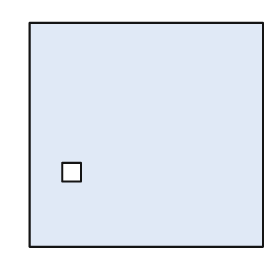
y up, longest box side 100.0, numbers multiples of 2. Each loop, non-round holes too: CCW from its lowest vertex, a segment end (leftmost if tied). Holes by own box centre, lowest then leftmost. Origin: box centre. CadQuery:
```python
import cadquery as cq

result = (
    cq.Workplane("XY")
    .moveTo(-50.0, -48.0)
    .lineTo(50.0, -48.0)
    .lineTo(50.0, 48.0)
    .lineTo(-50.0, 48.0)
    .close()
    .moveTo(-36.0, -20.0)
    .lineTo(-28.0, -20.0)
    .lineTo(-28.0, -12.0)
    .lineTo(-36.0, -12.0)
    .close()
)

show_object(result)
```